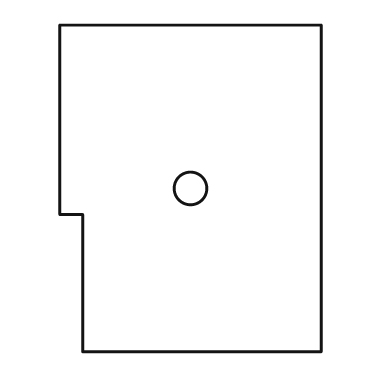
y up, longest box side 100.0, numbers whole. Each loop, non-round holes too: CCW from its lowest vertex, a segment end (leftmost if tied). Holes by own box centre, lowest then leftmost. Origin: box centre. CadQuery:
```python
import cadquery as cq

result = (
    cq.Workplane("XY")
    .moveTo(-33.0, -50.0)
    .lineTo(40.0, -50.0)
    .lineTo(40.0, 50.0)
    .lineTo(-40.0, 50.0)
    .lineTo(-40.0, -8.0)
    .lineTo(-33.0, -8.0)
    .close()
    .moveTo(0.0, 0.0)
    .circle(5.0)
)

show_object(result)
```